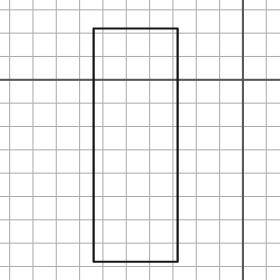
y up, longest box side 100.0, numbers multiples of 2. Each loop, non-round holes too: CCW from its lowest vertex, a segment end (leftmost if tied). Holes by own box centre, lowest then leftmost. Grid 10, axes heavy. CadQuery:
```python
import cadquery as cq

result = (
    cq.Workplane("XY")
    .moveTo(-64.0, -78.0)
    .lineTo(-28.0, -78.0)
    .lineTo(-28.0, 22.0)
    .lineTo(-64.0, 22.0)
    .close()
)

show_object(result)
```